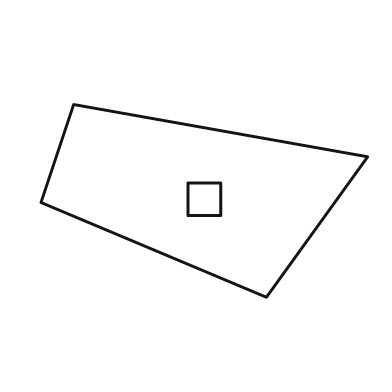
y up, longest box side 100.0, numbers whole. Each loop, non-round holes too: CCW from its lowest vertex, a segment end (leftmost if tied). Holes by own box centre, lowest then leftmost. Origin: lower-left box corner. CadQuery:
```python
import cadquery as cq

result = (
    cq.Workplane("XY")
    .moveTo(69.0, 0.0)
    .lineTo(100.0, 43.0)
    .lineTo(10.0, 59.0)
    .lineTo(0.0, 29.0)
    .close()
    .moveTo(45.0, 25.0)
    .lineTo(55.0, 25.0)
    .lineTo(55.0, 35.0)
    .lineTo(45.0, 35.0)
    .close()
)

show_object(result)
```